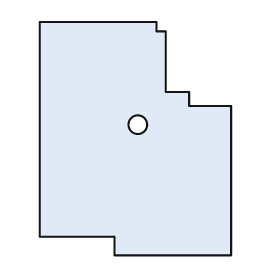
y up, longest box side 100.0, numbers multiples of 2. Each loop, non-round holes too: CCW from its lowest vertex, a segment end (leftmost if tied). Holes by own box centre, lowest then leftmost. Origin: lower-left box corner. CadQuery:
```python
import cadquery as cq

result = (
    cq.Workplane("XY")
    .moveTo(32.0, 0.0)
    .lineTo(82.0, 0.0)
    .lineTo(82.0, 64.0)
    .lineTo(64.0, 64.0)
    .lineTo(64.0, 70.0)
    .lineTo(54.0, 70.0)
    .lineTo(54.0, 96.0)
    .lineTo(50.0, 96.0)
    .lineTo(50.0, 100.0)
    .lineTo(0.0, 100.0)
    .lineTo(0.0, 8.0)
    .lineTo(32.0, 8.0)
    .close()
    .moveTo(42.0, 56.0)
    .circle(4.0)
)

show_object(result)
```